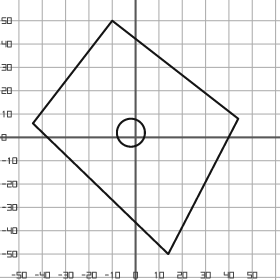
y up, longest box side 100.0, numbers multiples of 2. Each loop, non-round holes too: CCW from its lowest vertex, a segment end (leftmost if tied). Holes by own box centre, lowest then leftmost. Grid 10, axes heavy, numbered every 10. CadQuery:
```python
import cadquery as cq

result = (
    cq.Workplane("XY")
    .moveTo(14.0, -50.0)
    .lineTo(44.0, 8.0)
    .lineTo(-10.0, 50.0)
    .lineTo(-44.0, 6.0)
    .close()
    .moveTo(-2.0, 2.0)
    .circle(6.0)
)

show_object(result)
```